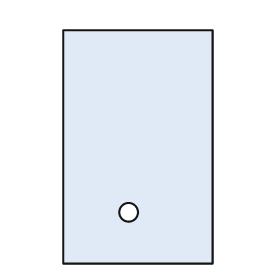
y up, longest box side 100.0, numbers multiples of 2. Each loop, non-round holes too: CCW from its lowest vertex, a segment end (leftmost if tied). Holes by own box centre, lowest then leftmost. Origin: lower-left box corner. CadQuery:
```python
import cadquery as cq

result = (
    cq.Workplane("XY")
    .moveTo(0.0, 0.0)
    .lineTo(64.0, 0.0)
    .lineTo(64.0, 100.0)
    .lineTo(0.0, 100.0)
    .close()
    .moveTo(28.0, 22.0)
    .circle(4.0)
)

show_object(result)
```